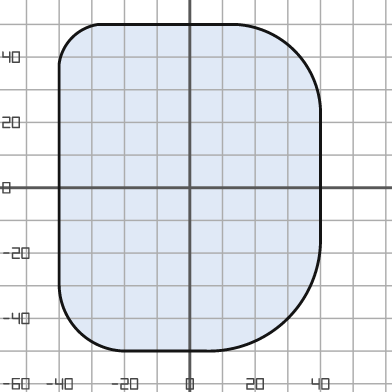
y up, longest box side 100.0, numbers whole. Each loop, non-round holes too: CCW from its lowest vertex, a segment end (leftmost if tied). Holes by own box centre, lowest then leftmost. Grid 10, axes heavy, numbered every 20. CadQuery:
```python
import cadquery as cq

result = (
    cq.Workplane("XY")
    .moveTo(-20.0, -50.0)
    .lineTo(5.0, -50.0)
    .threePointArc((30.0, -40.0), (40.0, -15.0))
    .lineTo(40.0, 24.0)
    .threePointArc((32.0, 42.0), (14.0, 50.0))
    .lineTo(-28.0, 50.0)
    .threePointArc((-36.0, 46.0), (-40.0, 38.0))
    .lineTo(-40.0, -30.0)
    .threePointArc((-34.0, -44.0), (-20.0, -50.0))
    .close()
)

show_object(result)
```